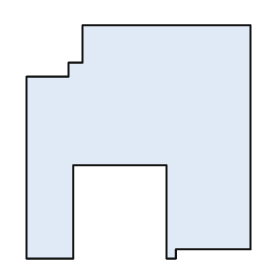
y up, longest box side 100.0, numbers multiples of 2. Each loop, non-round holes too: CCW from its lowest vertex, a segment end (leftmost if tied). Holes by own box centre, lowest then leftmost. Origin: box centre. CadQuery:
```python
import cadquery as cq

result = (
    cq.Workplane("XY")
    .moveTo(-48.0, -50.0)
    .lineTo(-28.0, -50.0)
    .lineTo(-28.0, -10.0)
    .lineTo(12.0, -10.0)
    .lineTo(12.0, -50.0)
    .lineTo(16.0, -50.0)
    .lineTo(16.0, -46.0)
    .lineTo(48.0, -46.0)
    .lineTo(48.0, 50.0)
    .lineTo(-24.0, 50.0)
    .lineTo(-24.0, 34.0)
    .lineTo(-30.0, 34.0)
    .lineTo(-30.0, 28.0)
    .lineTo(-48.0, 28.0)
    .close()
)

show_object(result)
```